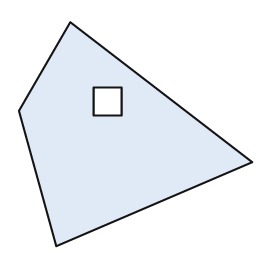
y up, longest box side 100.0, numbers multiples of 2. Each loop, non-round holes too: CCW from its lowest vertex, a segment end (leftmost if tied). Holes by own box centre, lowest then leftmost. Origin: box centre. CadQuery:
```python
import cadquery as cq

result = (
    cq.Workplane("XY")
    .moveTo(-34.0, -48.0)
    .lineTo(50.0, -12.0)
    .lineTo(-28.0, 48.0)
    .lineTo(-50.0, 10.0)
    .close()
    .moveTo(-18.0, 8.0)
    .lineTo(-6.0, 8.0)
    .lineTo(-6.0, 20.0)
    .lineTo(-18.0, 20.0)
    .close()
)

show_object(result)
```